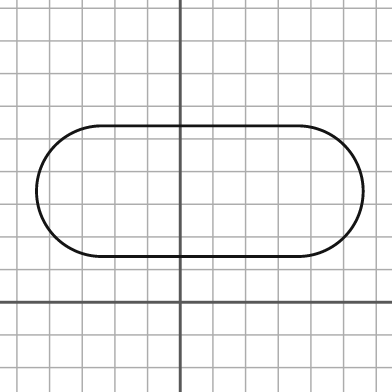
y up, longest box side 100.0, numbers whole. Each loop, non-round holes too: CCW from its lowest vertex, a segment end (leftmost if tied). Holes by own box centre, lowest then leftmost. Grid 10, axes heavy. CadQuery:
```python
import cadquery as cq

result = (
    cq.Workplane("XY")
    .moveTo(-24.0, 14.0)
    .lineTo(36.0, 14.0)
    .threePointArc((56.0, 34.0), (36.0, 54.0))
    .lineTo(-24.0, 54.0)
    .threePointArc((-44.0, 34.0), (-24.0, 14.0))
    .close()
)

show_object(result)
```